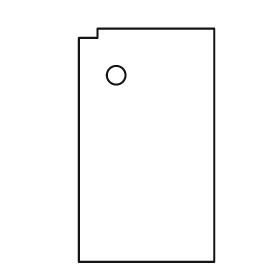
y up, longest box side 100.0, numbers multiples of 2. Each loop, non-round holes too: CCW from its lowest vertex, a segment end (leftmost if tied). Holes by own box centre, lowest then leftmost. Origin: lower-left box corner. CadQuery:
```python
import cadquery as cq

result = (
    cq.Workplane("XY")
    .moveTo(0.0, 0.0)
    .lineTo(58.0, 0.0)
    .lineTo(58.0, 100.0)
    .lineTo(8.0, 100.0)
    .lineTo(8.0, 96.0)
    .lineTo(0.0, 96.0)
    .close()
    .moveTo(16.0, 80.0)
    .circle(4.0)
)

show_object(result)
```